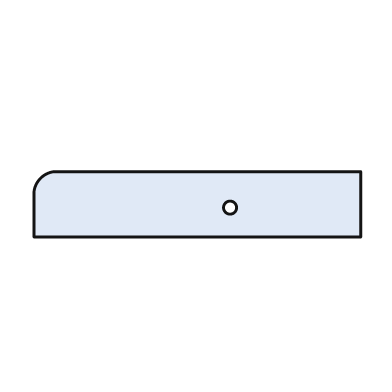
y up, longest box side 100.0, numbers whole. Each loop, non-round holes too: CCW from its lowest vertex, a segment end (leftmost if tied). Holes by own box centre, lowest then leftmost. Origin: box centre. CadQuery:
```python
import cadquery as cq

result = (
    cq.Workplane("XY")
    .moveTo(-50.0, -10.0)
    .lineTo(50.0, -10.0)
    .lineTo(50.0, 10.0)
    .lineTo(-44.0, 10.0)
    .threePointArc((-48.0, 8.0), (-50.0, 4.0))
    .close()
    .moveTo(10.0, -1.0)
    .circle(2.0)
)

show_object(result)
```